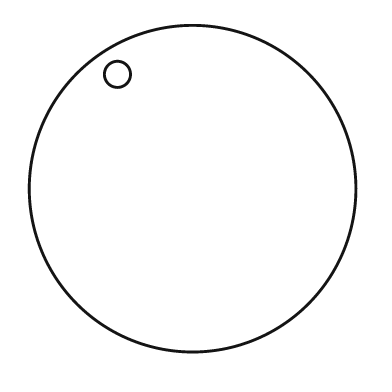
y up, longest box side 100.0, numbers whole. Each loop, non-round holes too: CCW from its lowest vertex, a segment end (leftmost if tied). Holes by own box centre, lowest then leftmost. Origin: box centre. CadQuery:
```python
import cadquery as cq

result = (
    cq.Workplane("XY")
    .moveTo(0.0, 0.0)
    .circle(50.0)
    .moveTo(-23.0, 35.0)
    .circle(4.0)
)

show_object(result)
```